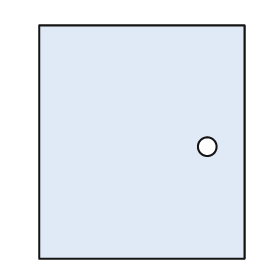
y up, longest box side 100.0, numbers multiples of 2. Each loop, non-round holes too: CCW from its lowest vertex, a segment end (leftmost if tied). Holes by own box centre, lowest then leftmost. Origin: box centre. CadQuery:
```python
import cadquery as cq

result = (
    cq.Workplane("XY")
    .moveTo(-44.0, -50.0)
    .lineTo(44.0, -50.0)
    .lineTo(44.0, 50.0)
    .lineTo(-44.0, 50.0)
    .close()
    .moveTo(28.0, -2.0)
    .circle(4.0)
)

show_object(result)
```